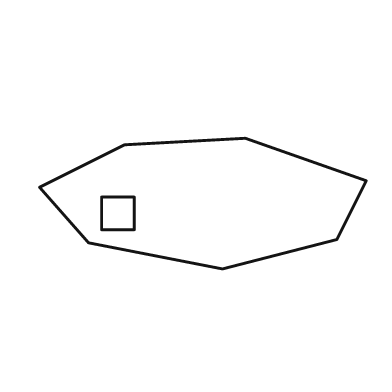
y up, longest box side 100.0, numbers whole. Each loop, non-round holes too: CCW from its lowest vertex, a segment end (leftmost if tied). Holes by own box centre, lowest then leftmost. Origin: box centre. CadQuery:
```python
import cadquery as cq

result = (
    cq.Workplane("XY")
    .moveTo(6.0, -20.0)
    .lineTo(41.0, -11.0)
    .lineTo(50.0, 7.0)
    .lineTo(13.0, 20.0)
    .lineTo(-24.0, 18.0)
    .lineTo(-50.0, 5.0)
    .lineTo(-35.0, -12.0)
    .close()
    .moveTo(-31.0, -8.0)
    .lineTo(-21.0, -8.0)
    .lineTo(-21.0, 2.0)
    .lineTo(-31.0, 2.0)
    .close()
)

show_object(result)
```